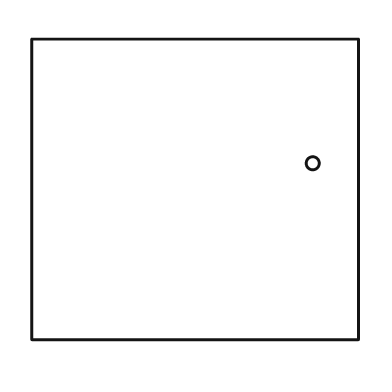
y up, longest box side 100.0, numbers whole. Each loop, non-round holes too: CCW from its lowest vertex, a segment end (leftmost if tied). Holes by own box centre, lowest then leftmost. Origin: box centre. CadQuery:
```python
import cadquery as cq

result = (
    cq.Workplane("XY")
    .moveTo(-50.0, -46.0)
    .lineTo(50.0, -46.0)
    .lineTo(50.0, 46.0)
    .lineTo(-50.0, 46.0)
    .close()
    .moveTo(36.0, 8.0)
    .circle(2.0)
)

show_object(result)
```